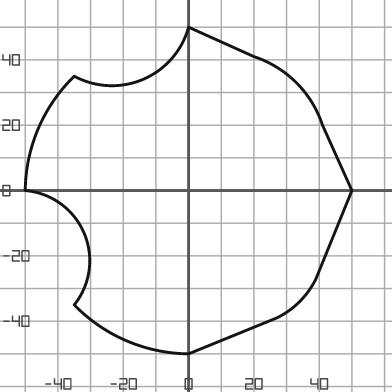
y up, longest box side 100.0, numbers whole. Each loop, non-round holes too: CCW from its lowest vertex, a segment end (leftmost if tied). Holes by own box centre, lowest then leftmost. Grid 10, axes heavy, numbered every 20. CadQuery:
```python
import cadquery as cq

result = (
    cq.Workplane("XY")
    .moveTo(0.0, -50.0)
    .lineTo(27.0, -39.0)
    .threePointArc((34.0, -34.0), (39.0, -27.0))
    .lineTo(50.0, 0.0)
    .lineTo(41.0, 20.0)
    .threePointArc((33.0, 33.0), (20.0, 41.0))
    .lineTo(0.0, 50.0)
    .threePointArc((-14.0, 34.0), (-35.0, 35.0))
    .threePointArc((-46.0, 19.0), (-50.0, 0.0))
    .threePointArc((-32.0, -13.0), (-35.0, -35.0))
    .threePointArc((-19.0, -46.0), (0.0, -50.0))
    .close()
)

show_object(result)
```